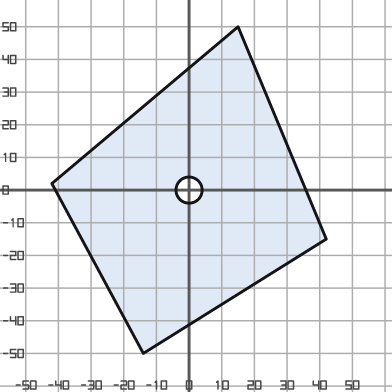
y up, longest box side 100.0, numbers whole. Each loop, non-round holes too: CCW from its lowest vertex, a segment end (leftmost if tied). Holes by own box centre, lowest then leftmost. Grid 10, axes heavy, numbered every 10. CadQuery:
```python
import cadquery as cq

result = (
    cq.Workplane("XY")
    .moveTo(-14.0, -50.0)
    .lineTo(42.0, -15.0)
    .lineTo(15.0, 50.0)
    .lineTo(-42.0, 2.0)
    .close()
    .moveTo(0.0, 0.0)
    .circle(4.0)
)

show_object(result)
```